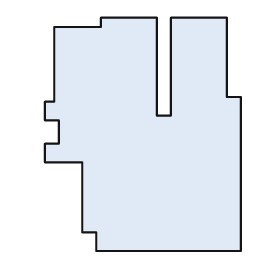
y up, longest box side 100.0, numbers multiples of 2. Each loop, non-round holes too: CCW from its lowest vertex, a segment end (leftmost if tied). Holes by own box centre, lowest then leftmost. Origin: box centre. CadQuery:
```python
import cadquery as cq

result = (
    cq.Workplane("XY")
    .moveTo(-20.0, -50.0)
    .lineTo(42.0, -50.0)
    .lineTo(42.0, 16.0)
    .lineTo(36.0, 16.0)
    .lineTo(36.0, 50.0)
    .lineTo(12.0, 50.0)
    .lineTo(12.0, 8.0)
    .lineTo(6.0, 8.0)
    .lineTo(6.0, 50.0)
    .lineTo(-18.0, 50.0)
    .lineTo(-18.0, 46.0)
    .lineTo(-38.0, 46.0)
    .lineTo(-38.0, 14.0)
    .lineTo(-42.0, 14.0)
    .lineTo(-42.0, 6.0)
    .lineTo(-36.0, 6.0)
    .lineTo(-36.0, -4.0)
    .lineTo(-42.0, -4.0)
    .lineTo(-42.0, -12.0)
    .lineTo(-26.0, -12.0)
    .lineTo(-26.0, -42.0)
    .lineTo(-20.0, -42.0)
    .close()
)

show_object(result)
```